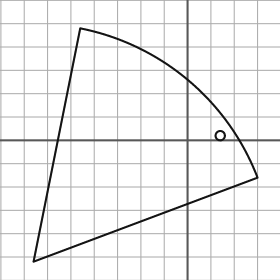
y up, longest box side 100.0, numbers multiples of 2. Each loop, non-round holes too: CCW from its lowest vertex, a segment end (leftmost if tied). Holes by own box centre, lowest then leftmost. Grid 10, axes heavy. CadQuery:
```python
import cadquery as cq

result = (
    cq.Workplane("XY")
    .moveTo(-66.0, -52.0)
    .lineTo(30.0, -16.0)
    .threePointArc((0.0, 26.0), (-46.0, 48.0))
    .close()
    .moveTo(14.0, 2.0)
    .circle(2.0)
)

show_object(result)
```